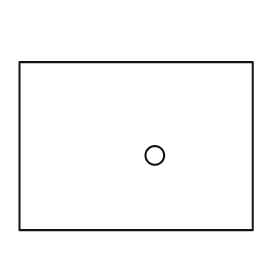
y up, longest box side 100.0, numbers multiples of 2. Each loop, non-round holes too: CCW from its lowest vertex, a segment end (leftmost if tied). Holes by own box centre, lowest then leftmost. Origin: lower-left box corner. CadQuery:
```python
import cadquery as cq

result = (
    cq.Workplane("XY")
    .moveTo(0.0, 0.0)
    .lineTo(100.0, 0.0)
    .lineTo(100.0, 72.0)
    .lineTo(0.0, 72.0)
    .close()
    .moveTo(58.0, 32.0)
    .circle(4.0)
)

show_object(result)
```